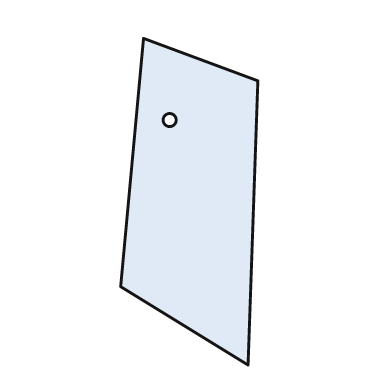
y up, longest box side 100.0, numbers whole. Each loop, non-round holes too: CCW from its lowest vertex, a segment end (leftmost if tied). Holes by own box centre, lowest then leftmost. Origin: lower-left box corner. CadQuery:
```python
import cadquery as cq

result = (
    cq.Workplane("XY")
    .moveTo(39.0, 0.0)
    .lineTo(42.0, 87.0)
    .lineTo(7.0, 100.0)
    .lineTo(0.0, 24.0)
    .close()
    .moveTo(15.0, 75.0)
    .circle(2.0)
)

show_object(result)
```